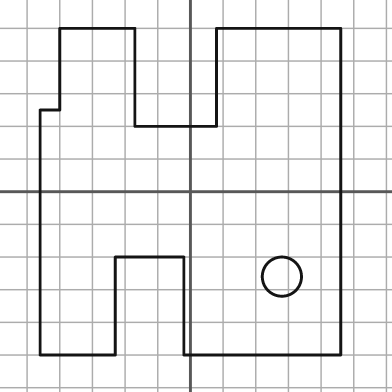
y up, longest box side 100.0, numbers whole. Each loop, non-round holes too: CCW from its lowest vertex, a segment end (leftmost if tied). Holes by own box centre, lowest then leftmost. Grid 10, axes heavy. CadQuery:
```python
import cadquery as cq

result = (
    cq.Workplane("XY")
    .moveTo(-46.0, -50.0)
    .lineTo(-23.0, -50.0)
    .lineTo(-23.0, -20.0)
    .lineTo(-2.0, -20.0)
    .lineTo(-2.0, -50.0)
    .lineTo(46.0, -50.0)
    .lineTo(46.0, 50.0)
    .lineTo(8.0, 50.0)
    .lineTo(8.0, 20.0)
    .lineTo(-17.0, 20.0)
    .lineTo(-17.0, 50.0)
    .lineTo(-40.0, 50.0)
    .lineTo(-40.0, 25.0)
    .lineTo(-46.0, 25.0)
    .close()
    .moveTo(28.0, -26.0)
    .circle(6.0)
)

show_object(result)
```